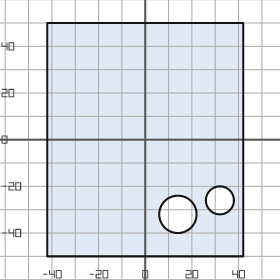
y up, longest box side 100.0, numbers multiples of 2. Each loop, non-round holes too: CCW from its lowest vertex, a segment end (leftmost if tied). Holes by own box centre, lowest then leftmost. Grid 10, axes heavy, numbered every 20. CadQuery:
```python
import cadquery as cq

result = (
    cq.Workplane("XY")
    .moveTo(-42.0, -50.0)
    .lineTo(42.0, -50.0)
    .lineTo(42.0, 50.0)
    .lineTo(-42.0, 50.0)
    .close()
    .moveTo(14.0, -32.0)
    .circle(8.0)
    .moveTo(32.0, -26.0)
    .circle(6.0)
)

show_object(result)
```